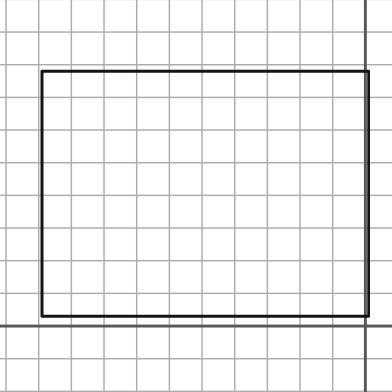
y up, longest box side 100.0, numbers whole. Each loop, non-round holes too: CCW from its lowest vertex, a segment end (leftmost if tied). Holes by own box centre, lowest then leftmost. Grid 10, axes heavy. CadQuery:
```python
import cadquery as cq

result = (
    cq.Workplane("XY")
    .moveTo(-99.0, 3.0)
    .lineTo(1.0, 3.0)
    .lineTo(1.0, 78.0)
    .lineTo(-99.0, 78.0)
    .close()
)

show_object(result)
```